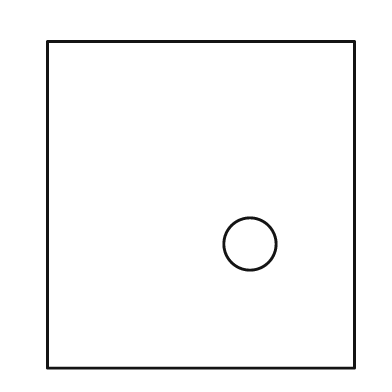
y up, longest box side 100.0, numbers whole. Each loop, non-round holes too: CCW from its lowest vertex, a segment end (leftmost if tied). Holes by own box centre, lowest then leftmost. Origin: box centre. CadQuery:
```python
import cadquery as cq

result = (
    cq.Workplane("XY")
    .moveTo(-47.0, -50.0)
    .lineTo(47.0, -50.0)
    .lineTo(47.0, 50.0)
    .lineTo(-47.0, 50.0)
    .close()
    .moveTo(15.0, -12.0)
    .circle(8.0)
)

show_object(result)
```